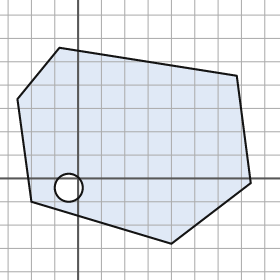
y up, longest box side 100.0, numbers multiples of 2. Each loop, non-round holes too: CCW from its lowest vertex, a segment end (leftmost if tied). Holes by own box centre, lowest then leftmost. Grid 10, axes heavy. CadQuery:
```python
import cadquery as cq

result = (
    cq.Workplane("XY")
    .moveTo(40.0, -28.0)
    .lineTo(74.0, -2.0)
    .lineTo(68.0, 44.0)
    .lineTo(-8.0, 56.0)
    .lineTo(-26.0, 34.0)
    .lineTo(-20.0, -10.0)
    .close()
    .moveTo(-4.0, -4.0)
    .circle(6.0)
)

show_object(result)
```